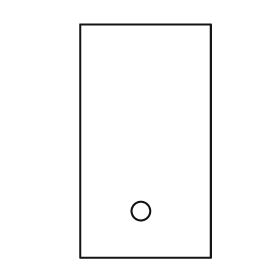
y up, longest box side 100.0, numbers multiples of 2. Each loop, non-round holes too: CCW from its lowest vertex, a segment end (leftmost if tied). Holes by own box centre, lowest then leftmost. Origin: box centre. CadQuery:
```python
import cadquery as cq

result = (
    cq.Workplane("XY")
    .moveTo(-28.0, -50.0)
    .lineTo(28.0, -50.0)
    .lineTo(28.0, 50.0)
    .lineTo(-28.0, 50.0)
    .close()
    .moveTo(-2.0, -30.0)
    .circle(4.0)
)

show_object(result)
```